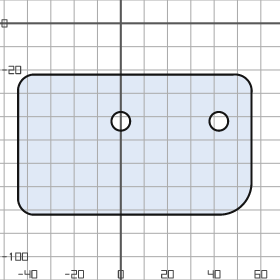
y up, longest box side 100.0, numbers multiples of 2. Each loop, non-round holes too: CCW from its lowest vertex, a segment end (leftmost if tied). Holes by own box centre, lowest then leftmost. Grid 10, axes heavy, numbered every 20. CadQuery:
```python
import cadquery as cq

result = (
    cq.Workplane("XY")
    .moveTo(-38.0, -82.0)
    .lineTo(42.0, -82.0)
    .threePointArc((52.0, -78.0), (56.0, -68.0))
    .lineTo(56.0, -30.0)
    .threePointArc((54.0, -24.0), (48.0, -22.0))
    .lineTo(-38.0, -22.0)
    .threePointArc((-42.0, -24.0), (-44.0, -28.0))
    .lineTo(-44.0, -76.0)
    .threePointArc((-42.0, -80.0), (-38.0, -82.0))
    .close()
    .moveTo(0.0, -42.0)
    .circle(4.0)
    .moveTo(42.0, -42.0)
    .circle(4.0)
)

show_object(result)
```